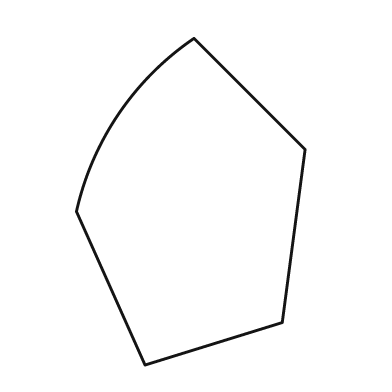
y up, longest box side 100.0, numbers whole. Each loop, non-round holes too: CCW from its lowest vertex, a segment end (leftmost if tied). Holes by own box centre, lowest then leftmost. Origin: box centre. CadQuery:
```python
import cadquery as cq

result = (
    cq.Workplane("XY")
    .moveTo(-14.0, -50.0)
    .lineTo(28.0, -37.0)
    .lineTo(35.0, 16.0)
    .lineTo(1.0, 50.0)
    .threePointArc((-22.0, 27.0), (-35.0, -3.0))
    .close()
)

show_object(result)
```